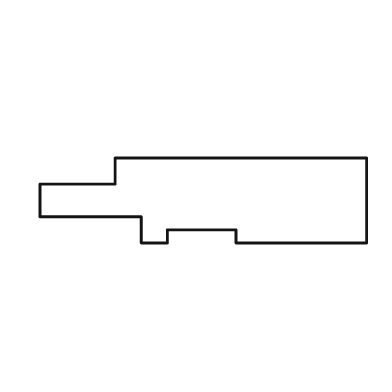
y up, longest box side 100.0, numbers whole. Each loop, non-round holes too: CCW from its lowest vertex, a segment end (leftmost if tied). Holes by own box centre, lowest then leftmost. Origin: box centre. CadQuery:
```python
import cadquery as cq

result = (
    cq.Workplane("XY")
    .moveTo(-19.0, -13.0)
    .lineTo(-11.0, -13.0)
    .lineTo(-11.0, -9.0)
    .lineTo(10.0, -9.0)
    .lineTo(10.0, -13.0)
    .lineTo(50.0, -13.0)
    .lineTo(50.0, 13.0)
    .lineTo(-27.0, 13.0)
    .lineTo(-27.0, 5.0)
    .lineTo(-50.0, 5.0)
    .lineTo(-50.0, -5.0)
    .lineTo(-19.0, -5.0)
    .close()
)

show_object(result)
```